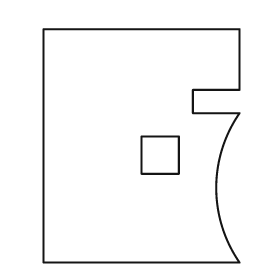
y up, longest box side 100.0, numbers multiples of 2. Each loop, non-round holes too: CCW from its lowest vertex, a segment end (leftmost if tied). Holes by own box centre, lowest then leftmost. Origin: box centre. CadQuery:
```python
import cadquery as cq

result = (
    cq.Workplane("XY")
    .moveTo(-42.0, -50.0)
    .lineTo(42.0, -50.0)
    .threePointArc((32.0, -18.0), (42.0, 14.0))
    .lineTo(22.0, 14.0)
    .lineTo(22.0, 24.0)
    .lineTo(42.0, 24.0)
    .lineTo(42.0, 50.0)
    .lineTo(-42.0, 50.0)
    .close()
    .moveTo(0.0, -12.0)
    .lineTo(16.0, -12.0)
    .lineTo(16.0, 4.0)
    .lineTo(0.0, 4.0)
    .close()
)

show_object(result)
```